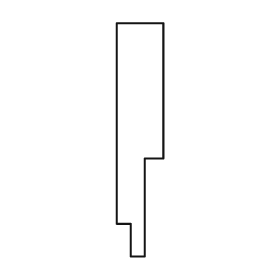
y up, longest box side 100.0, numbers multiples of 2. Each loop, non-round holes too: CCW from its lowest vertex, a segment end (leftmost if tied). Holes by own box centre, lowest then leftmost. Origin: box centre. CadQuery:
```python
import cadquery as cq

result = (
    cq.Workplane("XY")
    .moveTo(-4.0, -50.0)
    .lineTo(2.0, -50.0)
    .lineTo(2.0, -8.0)
    .lineTo(10.0, -8.0)
    .lineTo(10.0, 50.0)
    .lineTo(-10.0, 50.0)
    .lineTo(-10.0, -36.0)
    .lineTo(-4.0, -36.0)
    .close()
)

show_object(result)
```